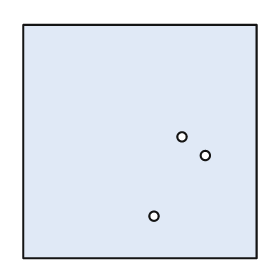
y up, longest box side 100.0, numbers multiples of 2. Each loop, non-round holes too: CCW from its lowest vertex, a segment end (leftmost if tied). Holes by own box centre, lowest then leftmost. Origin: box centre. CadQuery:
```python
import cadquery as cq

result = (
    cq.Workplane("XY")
    .moveTo(-50.0, -50.0)
    .lineTo(50.0, -50.0)
    .lineTo(50.0, 50.0)
    .lineTo(-50.0, 50.0)
    .close()
    .moveTo(6.0, -32.0)
    .circle(2.0)
    .moveTo(28.0, -6.0)
    .circle(2.0)
    .moveTo(18.0, 2.0)
    .circle(2.0)
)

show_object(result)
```